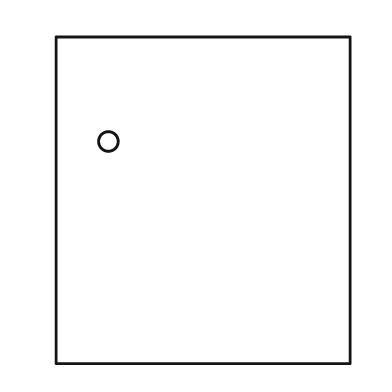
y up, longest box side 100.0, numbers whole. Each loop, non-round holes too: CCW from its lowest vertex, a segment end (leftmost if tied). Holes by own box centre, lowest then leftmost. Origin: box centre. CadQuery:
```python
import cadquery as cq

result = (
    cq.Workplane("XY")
    .moveTo(-45.0, -50.0)
    .lineTo(45.0, -50.0)
    .lineTo(45.0, 50.0)
    .lineTo(-45.0, 50.0)
    .close()
    .moveTo(-29.0, 18.0)
    .circle(3.0)
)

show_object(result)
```